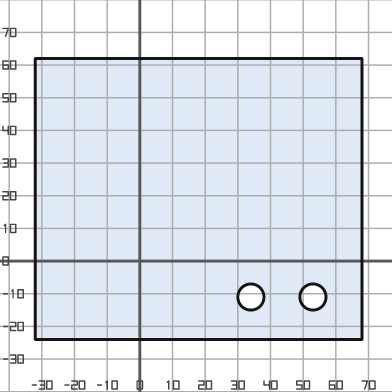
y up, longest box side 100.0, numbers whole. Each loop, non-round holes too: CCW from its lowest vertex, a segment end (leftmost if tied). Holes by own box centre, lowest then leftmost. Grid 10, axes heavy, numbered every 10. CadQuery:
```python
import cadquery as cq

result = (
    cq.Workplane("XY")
    .moveTo(-32.0, -24.0)
    .lineTo(68.0, -24.0)
    .lineTo(68.0, 62.0)
    .lineTo(-32.0, 62.0)
    .close()
    .moveTo(34.0, -11.0)
    .circle(4.0)
    .moveTo(53.0, -11.0)
    .circle(4.0)
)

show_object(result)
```